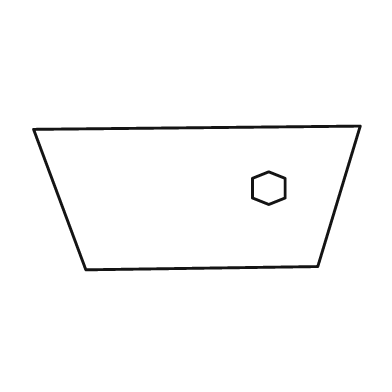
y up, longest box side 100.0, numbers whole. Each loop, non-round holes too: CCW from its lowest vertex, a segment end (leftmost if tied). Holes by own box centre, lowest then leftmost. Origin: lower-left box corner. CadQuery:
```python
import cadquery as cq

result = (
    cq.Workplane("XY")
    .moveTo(16.0, 0.0)
    .lineTo(87.0, 1.0)
    .lineTo(100.0, 44.0)
    .lineTo(0.0, 43.0)
    .close()
    .moveTo(72.0, 20.0)
    .lineTo(77.0, 22.0)
    .lineTo(77.0, 28.0)
    .lineTo(72.0, 30.0)
    .lineTo(67.0, 28.0)
    .lineTo(67.0, 22.0)
    .close()
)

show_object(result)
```